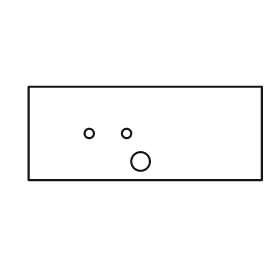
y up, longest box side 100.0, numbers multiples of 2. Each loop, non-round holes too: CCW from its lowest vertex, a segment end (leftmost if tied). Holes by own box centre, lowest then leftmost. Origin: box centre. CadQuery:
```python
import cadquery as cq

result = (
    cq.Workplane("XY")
    .moveTo(-50.0, -20.0)
    .lineTo(50.0, -20.0)
    .lineTo(50.0, 20.0)
    .lineTo(-50.0, 20.0)
    .close()
    .moveTo(-2.0, -12.0)
    .circle(4.0)
    .moveTo(-24.0, 0.0)
    .circle(2.0)
    .moveTo(-8.0, 0.0)
    .circle(2.0)
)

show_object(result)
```